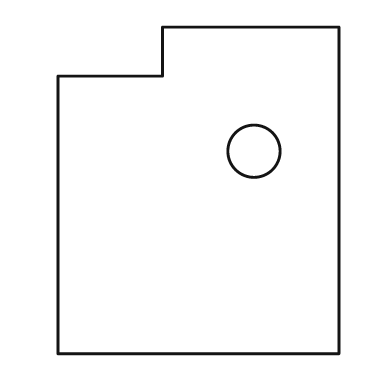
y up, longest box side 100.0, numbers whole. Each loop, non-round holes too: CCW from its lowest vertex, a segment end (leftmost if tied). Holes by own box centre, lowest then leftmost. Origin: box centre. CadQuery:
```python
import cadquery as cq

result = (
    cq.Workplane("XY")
    .moveTo(-43.0, -50.0)
    .lineTo(43.0, -50.0)
    .lineTo(43.0, 50.0)
    .lineTo(-11.0, 50.0)
    .lineTo(-11.0, 35.0)
    .lineTo(-43.0, 35.0)
    .close()
    .moveTo(17.0, 12.0)
    .circle(8.0)
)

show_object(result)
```